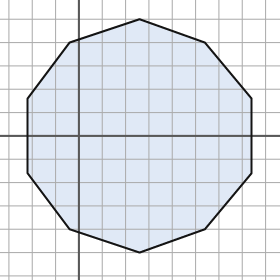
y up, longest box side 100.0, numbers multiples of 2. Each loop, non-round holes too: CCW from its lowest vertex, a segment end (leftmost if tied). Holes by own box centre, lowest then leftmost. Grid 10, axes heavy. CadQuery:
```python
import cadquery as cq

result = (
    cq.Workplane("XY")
    .moveTo(26.0, -50.0)
    .lineTo(54.0, -40.0)
    .lineTo(74.0, -16.0)
    .lineTo(74.0, 16.0)
    .lineTo(54.0, 40.0)
    .lineTo(26.0, 50.0)
    .lineTo(-4.0, 40.0)
    .lineTo(-22.0, 16.0)
    .lineTo(-22.0, -16.0)
    .lineTo(-4.0, -40.0)
    .close()
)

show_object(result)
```